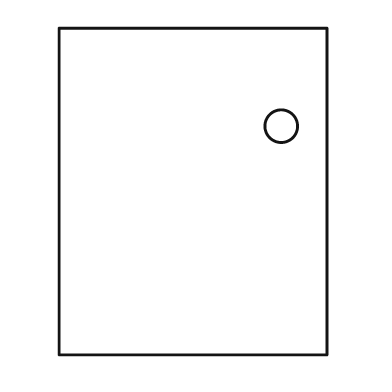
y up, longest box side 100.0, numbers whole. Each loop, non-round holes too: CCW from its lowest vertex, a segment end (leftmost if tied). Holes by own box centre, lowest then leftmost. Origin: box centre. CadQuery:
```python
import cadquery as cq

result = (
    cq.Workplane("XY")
    .moveTo(-41.0, -50.0)
    .lineTo(41.0, -50.0)
    .lineTo(41.0, 50.0)
    .lineTo(-41.0, 50.0)
    .close()
    .moveTo(27.0, 20.0)
    .circle(5.0)
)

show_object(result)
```